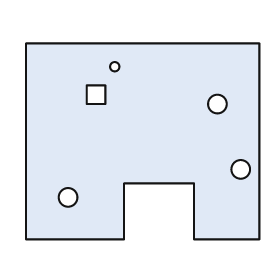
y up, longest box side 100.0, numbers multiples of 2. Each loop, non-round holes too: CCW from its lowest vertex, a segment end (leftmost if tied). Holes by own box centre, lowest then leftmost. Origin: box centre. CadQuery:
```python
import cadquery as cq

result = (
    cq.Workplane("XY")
    .moveTo(-50.0, -42.0)
    .lineTo(-8.0, -42.0)
    .lineTo(-8.0, -18.0)
    .lineTo(22.0, -18.0)
    .lineTo(22.0, -42.0)
    .lineTo(50.0, -42.0)
    .lineTo(50.0, 42.0)
    .lineTo(-50.0, 42.0)
    .close()
    .moveTo(-32.0, -24.0)
    .circle(4.0)
    .moveTo(42.0, -12.0)
    .circle(4.0)
    .moveTo(32.0, 16.0)
    .circle(4.0)
    .moveTo(-24.0, 16.0)
    .lineTo(-16.0, 16.0)
    .lineTo(-16.0, 24.0)
    .lineTo(-24.0, 24.0)
    .close()
    .moveTo(-12.0, 32.0)
    .circle(2.0)
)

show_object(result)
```